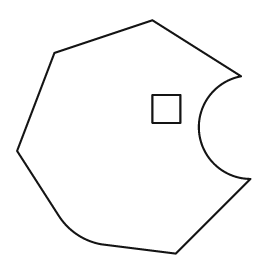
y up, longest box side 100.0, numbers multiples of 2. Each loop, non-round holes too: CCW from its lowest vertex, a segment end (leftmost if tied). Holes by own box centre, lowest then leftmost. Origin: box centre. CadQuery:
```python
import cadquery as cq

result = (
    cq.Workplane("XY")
    .moveTo(18.0, -50.0)
    .lineTo(50.0, -18.0)
    .threePointArc((28.0, 2.0), (46.0, 26.0))
    .lineTo(8.0, 50.0)
    .lineTo(-34.0, 36.0)
    .lineTo(-50.0, -6.0)
    .lineTo(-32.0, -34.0)
    .threePointArc((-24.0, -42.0), (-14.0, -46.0))
    .close()
    .moveTo(8.0, 6.0)
    .lineTo(20.0, 6.0)
    .lineTo(20.0, 18.0)
    .lineTo(8.0, 18.0)
    .close()
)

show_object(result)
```